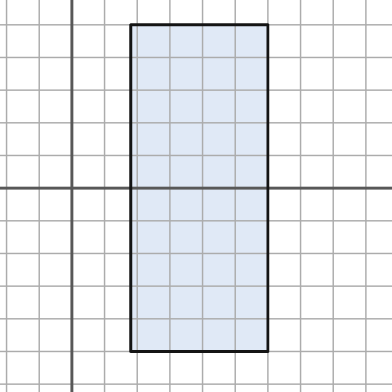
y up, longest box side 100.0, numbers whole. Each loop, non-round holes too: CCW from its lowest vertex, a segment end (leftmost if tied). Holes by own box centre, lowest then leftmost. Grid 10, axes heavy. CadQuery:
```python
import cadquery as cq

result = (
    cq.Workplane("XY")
    .moveTo(18.0, -50.0)
    .lineTo(60.0, -50.0)
    .lineTo(60.0, 50.0)
    .lineTo(18.0, 50.0)
    .close()
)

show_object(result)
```